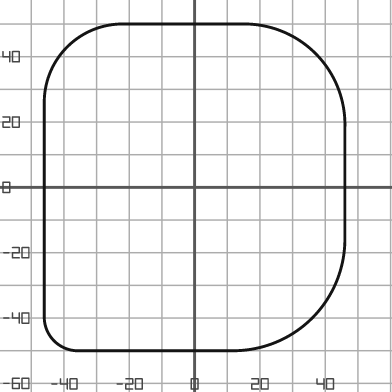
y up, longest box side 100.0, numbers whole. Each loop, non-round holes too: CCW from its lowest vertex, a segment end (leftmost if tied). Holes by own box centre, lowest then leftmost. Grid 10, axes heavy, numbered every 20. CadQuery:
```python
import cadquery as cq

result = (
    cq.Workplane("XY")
    .moveTo(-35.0, -50.0)
    .lineTo(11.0, -50.0)
    .threePointArc((36.0, -40.0), (46.0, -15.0))
    .lineTo(46.0, 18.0)
    .threePointArc((37.0, 41.0), (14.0, 50.0))
    .lineTo(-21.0, 50.0)
    .threePointArc((-39.0, 43.0), (-46.0, 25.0))
    .lineTo(-46.0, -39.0)
    .threePointArc((-43.0, -47.0), (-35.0, -50.0))
    .close()
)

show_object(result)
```